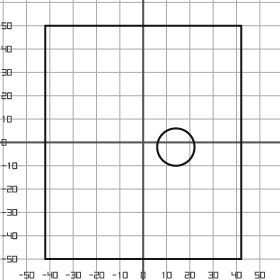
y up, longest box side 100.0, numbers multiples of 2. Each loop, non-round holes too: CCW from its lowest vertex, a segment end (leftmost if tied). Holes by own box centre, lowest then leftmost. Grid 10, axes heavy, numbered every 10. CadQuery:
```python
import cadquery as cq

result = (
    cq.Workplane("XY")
    .moveTo(-42.0, -50.0)
    .lineTo(42.0, -50.0)
    .lineTo(42.0, 50.0)
    .lineTo(-42.0, 50.0)
    .close()
    .moveTo(14.0, -2.0)
    .circle(8.0)
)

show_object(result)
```